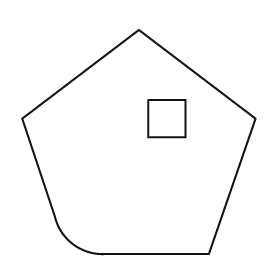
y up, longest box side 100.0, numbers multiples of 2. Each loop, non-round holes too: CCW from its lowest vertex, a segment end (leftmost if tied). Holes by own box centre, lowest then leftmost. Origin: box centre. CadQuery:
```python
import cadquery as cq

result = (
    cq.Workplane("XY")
    .moveTo(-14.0, -48.0)
    .lineTo(30.0, -48.0)
    .lineTo(50.0, 10.0)
    .lineTo(0.0, 48.0)
    .lineTo(-50.0, 10.0)
    .lineTo(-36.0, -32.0)
    .threePointArc((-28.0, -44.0), (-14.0, -48.0))
    .close()
    .moveTo(4.0, 2.0)
    .lineTo(20.0, 2.0)
    .lineTo(20.0, 18.0)
    .lineTo(4.0, 18.0)
    .close()
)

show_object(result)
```